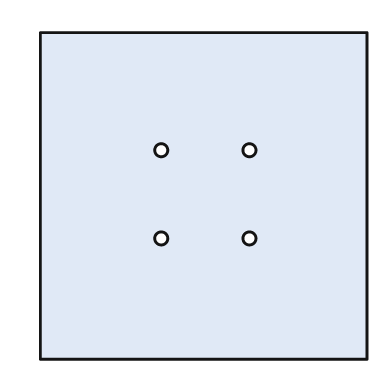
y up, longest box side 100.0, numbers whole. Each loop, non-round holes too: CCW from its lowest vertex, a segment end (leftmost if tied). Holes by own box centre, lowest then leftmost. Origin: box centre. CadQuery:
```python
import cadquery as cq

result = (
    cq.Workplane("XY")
    .moveTo(-50.0, -50.0)
    .lineTo(50.0, -50.0)
    .lineTo(50.0, 50.0)
    .lineTo(-50.0, 50.0)
    .close()
    .moveTo(-13.0, -13.0)
    .circle(2.0)
    .moveTo(14.0, -13.0)
    .circle(2.0)
    .moveTo(-13.0, 14.0)
    .circle(2.0)
    .moveTo(14.0, 14.0)
    .circle(2.0)
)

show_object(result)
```